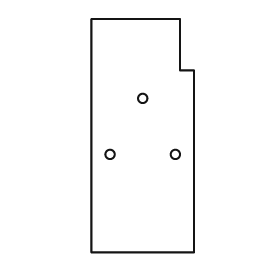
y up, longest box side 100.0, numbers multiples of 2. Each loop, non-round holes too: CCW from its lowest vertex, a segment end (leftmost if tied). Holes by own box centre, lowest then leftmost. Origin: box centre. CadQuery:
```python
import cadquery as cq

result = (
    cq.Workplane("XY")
    .moveTo(-22.0, -50.0)
    .lineTo(22.0, -50.0)
    .lineTo(22.0, 28.0)
    .lineTo(16.0, 28.0)
    .lineTo(16.0, 50.0)
    .lineTo(-22.0, 50.0)
    .close()
    .moveTo(-14.0, -8.0)
    .circle(2.0)
    .moveTo(14.0, -8.0)
    .circle(2.0)
    .moveTo(0.0, 16.0)
    .circle(2.0)
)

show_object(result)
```